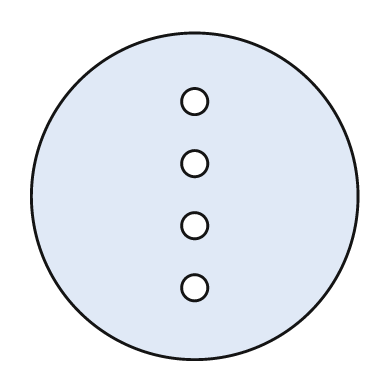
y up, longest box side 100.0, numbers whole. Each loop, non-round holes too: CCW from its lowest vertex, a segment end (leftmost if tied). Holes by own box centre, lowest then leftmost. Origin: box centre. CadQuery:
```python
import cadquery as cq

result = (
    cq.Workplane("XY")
    .moveTo(0.0, 0.0)
    .circle(50.0)
    .moveTo(0.0, -28.0)
    .circle(4.0)
    .moveTo(0.0, -9.0)
    .circle(4.0)
    .moveTo(0.0, 10.0)
    .circle(4.0)
    .moveTo(0.0, 29.0)
    .circle(4.0)
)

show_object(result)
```